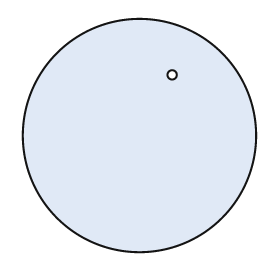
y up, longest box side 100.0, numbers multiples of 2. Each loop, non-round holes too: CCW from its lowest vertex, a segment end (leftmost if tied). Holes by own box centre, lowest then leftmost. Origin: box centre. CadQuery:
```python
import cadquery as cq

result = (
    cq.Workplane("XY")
    .moveTo(0.0, 0.0)
    .circle(50.0)
    .moveTo(14.0, 26.0)
    .circle(2.0)
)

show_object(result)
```